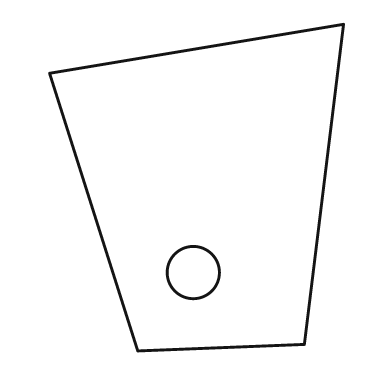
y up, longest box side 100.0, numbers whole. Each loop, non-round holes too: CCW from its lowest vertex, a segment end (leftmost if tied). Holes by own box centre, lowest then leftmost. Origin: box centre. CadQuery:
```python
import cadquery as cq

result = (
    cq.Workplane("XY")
    .moveTo(-18.0, -50.0)
    .lineTo(33.0, -48.0)
    .lineTo(45.0, 50.0)
    .lineTo(-45.0, 35.0)
    .close()
    .moveTo(-1.0, -26.0)
    .circle(8.0)
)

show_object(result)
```